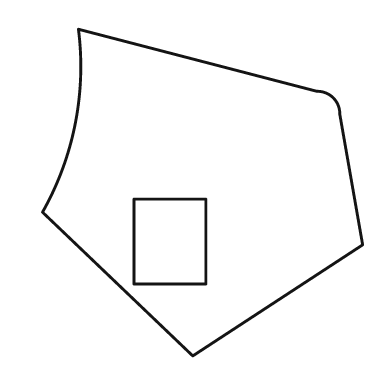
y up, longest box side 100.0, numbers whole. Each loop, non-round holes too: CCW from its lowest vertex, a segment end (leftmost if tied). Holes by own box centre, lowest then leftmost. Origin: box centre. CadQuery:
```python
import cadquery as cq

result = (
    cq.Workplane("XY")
    .moveTo(-3.0, -50.0)
    .lineTo(49.0, -16.0)
    .lineTo(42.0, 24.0)
    .threePointArc((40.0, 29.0), (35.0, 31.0))
    .lineTo(-38.0, 50.0)
    .threePointArc((-39.0, 21.0), (-49.0, -6.0))
    .close()
    .moveTo(-21.0, -28.0)
    .lineTo(1.0, -28.0)
    .lineTo(1.0, -2.0)
    .lineTo(-21.0, -2.0)
    .close()
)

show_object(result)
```